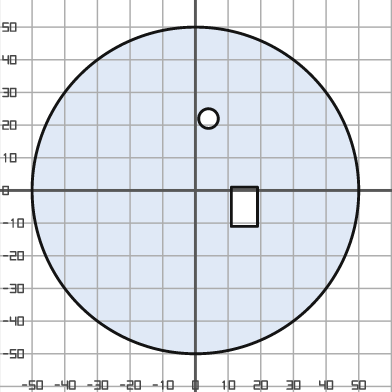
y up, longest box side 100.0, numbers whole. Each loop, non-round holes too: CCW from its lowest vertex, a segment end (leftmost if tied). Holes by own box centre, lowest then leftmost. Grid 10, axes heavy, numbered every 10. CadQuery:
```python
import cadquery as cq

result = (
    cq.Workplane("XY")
    .moveTo(0.0, 0.0)
    .circle(50.0)
    .moveTo(11.0, -11.0)
    .lineTo(19.0, -11.0)
    .lineTo(19.0, 1.0)
    .lineTo(11.0, 1.0)
    .close()
    .moveTo(4.0, 22.0)
    .circle(3.0)
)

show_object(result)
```